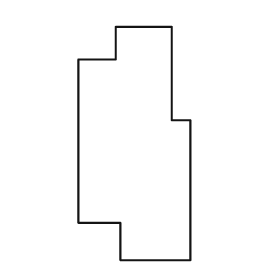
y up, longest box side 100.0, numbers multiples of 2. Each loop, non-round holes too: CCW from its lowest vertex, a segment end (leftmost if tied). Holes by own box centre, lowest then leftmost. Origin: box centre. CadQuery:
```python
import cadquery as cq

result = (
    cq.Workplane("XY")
    .moveTo(-6.0, -50.0)
    .lineTo(24.0, -50.0)
    .lineTo(24.0, 10.0)
    .lineTo(16.0, 10.0)
    .lineTo(16.0, 50.0)
    .lineTo(-8.0, 50.0)
    .lineTo(-8.0, 36.0)
    .lineTo(-24.0, 36.0)
    .lineTo(-24.0, -34.0)
    .lineTo(-6.0, -34.0)
    .close()
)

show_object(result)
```